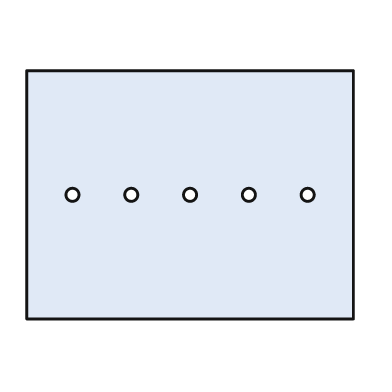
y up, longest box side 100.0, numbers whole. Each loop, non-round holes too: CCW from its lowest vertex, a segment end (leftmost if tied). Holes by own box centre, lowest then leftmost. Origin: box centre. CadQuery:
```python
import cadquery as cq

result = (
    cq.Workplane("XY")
    .moveTo(-50.0, -38.0)
    .lineTo(50.0, -38.0)
    .lineTo(50.0, 38.0)
    .lineTo(-50.0, 38.0)
    .close()
    .moveTo(-36.0, 0.0)
    .circle(2.0)
    .moveTo(-18.0, 0.0)
    .circle(2.0)
    .moveTo(0.0, 0.0)
    .circle(2.0)
    .moveTo(18.0, 0.0)
    .circle(2.0)
    .moveTo(36.0, 0.0)
    .circle(2.0)
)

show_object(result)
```